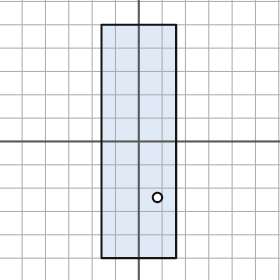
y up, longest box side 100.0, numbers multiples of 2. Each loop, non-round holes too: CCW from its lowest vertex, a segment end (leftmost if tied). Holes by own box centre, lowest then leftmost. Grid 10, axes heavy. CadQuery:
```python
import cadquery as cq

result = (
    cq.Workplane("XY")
    .moveTo(-16.0, -50.0)
    .lineTo(16.0, -50.0)
    .lineTo(16.0, 50.0)
    .lineTo(-16.0, 50.0)
    .close()
    .moveTo(8.0, -24.0)
    .circle(2.0)
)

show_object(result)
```